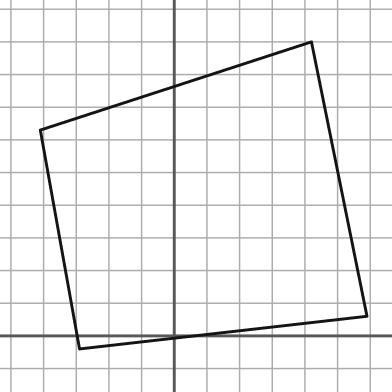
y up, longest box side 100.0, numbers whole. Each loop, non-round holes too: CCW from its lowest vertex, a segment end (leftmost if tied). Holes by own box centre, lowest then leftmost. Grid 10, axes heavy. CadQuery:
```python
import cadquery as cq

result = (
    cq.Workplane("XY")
    .moveTo(-29.0, -4.0)
    .lineTo(59.0, 6.0)
    .lineTo(42.0, 90.0)
    .lineTo(-41.0, 63.0)
    .close()
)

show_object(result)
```